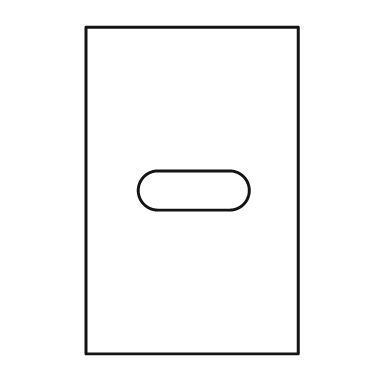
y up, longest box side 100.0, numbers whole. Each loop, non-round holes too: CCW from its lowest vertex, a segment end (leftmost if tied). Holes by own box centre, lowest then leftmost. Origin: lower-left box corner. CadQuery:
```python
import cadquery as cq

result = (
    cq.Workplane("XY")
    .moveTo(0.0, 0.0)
    .lineTo(65.0, 0.0)
    .lineTo(65.0, 100.0)
    .lineTo(0.0, 100.0)
    .close()
    .moveTo(22.0, 44.0)
    .lineTo(44.0, 44.0)
    .threePointArc((50.0, 50.0), (44.0, 56.0))
    .lineTo(22.0, 56.0)
    .threePointArc((16.0, 50.0), (22.0, 44.0))
    .close()
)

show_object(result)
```